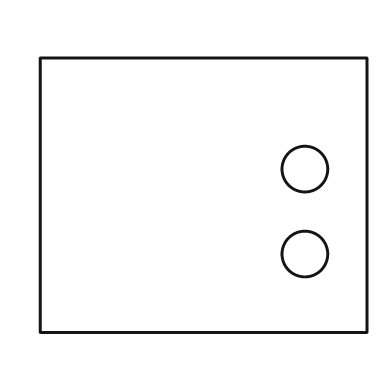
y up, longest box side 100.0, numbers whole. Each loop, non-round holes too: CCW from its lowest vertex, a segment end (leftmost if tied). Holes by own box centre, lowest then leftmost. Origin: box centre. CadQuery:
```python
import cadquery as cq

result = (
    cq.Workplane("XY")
    .moveTo(-50.0, -42.0)
    .lineTo(50.0, -42.0)
    .lineTo(50.0, 42.0)
    .lineTo(-50.0, 42.0)
    .close()
    .moveTo(31.0, -18.0)
    .circle(7.0)
    .moveTo(31.0, 8.0)
    .circle(7.0)
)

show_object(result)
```